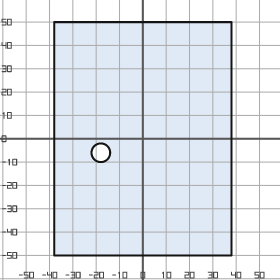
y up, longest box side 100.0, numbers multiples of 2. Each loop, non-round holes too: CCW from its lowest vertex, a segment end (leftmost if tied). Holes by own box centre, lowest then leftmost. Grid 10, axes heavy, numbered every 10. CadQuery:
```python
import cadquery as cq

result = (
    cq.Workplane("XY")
    .moveTo(-38.0, -50.0)
    .lineTo(38.0, -50.0)
    .lineTo(38.0, 50.0)
    .lineTo(-38.0, 50.0)
    .close()
    .moveTo(-18.0, -6.0)
    .circle(4.0)
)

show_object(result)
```